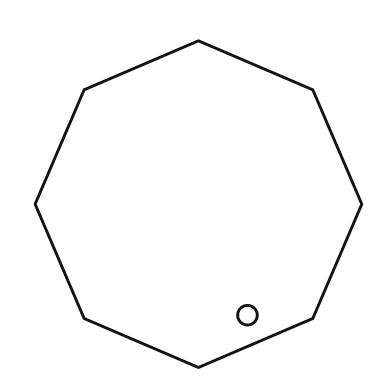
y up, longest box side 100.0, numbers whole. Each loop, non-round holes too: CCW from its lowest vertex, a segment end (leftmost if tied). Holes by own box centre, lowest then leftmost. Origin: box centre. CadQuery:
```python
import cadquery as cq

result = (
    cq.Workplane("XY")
    .moveTo(0.0, -50.0)
    .lineTo(35.0, -35.0)
    .lineTo(50.0, 0.0)
    .lineTo(35.0, 35.0)
    .lineTo(0.0, 50.0)
    .lineTo(-35.0, 35.0)
    .lineTo(-50.0, 0.0)
    .lineTo(-35.0, -35.0)
    .close()
    .moveTo(15.0, -34.0)
    .circle(3.0)
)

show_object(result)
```